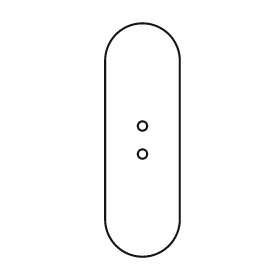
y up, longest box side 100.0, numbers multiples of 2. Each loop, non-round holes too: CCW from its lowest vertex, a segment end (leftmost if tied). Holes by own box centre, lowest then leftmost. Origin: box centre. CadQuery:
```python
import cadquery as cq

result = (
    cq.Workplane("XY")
    .moveTo(-16.0, -34.0)
    .threePointArc((0.0, -50.0), (16.0, -34.0))
    .lineTo(16.0, 34.0)
    .threePointArc((0.0, 50.0), (-16.0, 34.0))
    .close()
    .moveTo(0.0, -6.0)
    .circle(2.0)
    .moveTo(0.0, 6.0)
    .circle(2.0)
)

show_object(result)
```